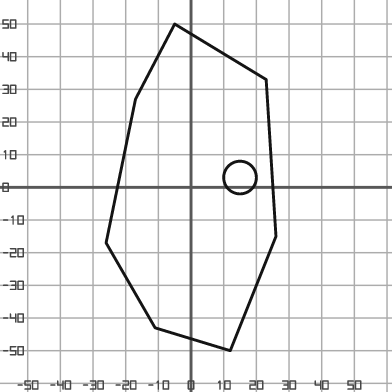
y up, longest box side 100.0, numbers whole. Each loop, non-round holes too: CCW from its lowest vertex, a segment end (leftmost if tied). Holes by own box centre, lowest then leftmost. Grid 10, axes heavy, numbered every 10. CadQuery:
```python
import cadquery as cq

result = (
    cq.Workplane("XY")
    .moveTo(12.0, -50.0)
    .lineTo(26.0, -15.0)
    .lineTo(23.0, 33.0)
    .lineTo(-5.0, 50.0)
    .lineTo(-17.0, 27.0)
    .lineTo(-26.0, -17.0)
    .lineTo(-11.0, -43.0)
    .close()
    .moveTo(15.0, 3.0)
    .circle(5.0)
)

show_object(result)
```